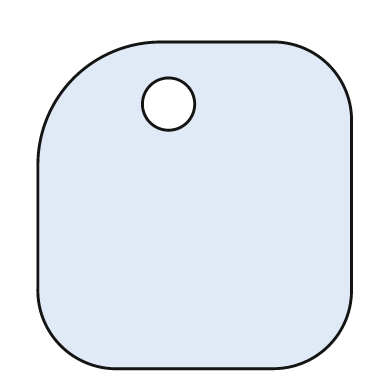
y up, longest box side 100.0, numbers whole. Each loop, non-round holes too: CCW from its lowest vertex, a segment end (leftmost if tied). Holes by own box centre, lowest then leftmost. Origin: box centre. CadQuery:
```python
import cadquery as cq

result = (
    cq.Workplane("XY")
    .moveTo(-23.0, -50.0)
    .lineTo(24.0, -50.0)
    .threePointArc((41.0, -43.0), (48.0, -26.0))
    .lineTo(48.0, 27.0)
    .threePointArc((41.0, 43.0), (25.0, 50.0))
    .lineTo(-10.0, 50.0)
    .threePointArc((-37.0, 39.0), (-48.0, 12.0))
    .lineTo(-48.0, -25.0)
    .threePointArc((-41.0, -43.0), (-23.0, -50.0))
    .close()
    .moveTo(-8.0, 31.0)
    .circle(8.0)
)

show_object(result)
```